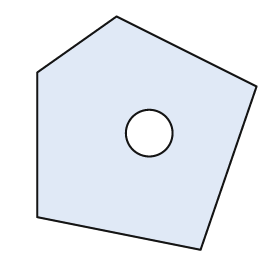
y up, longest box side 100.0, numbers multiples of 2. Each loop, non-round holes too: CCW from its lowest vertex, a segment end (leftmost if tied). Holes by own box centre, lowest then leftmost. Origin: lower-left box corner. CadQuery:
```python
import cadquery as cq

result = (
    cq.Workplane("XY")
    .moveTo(70.0, 0.0)
    .lineTo(94.0, 70.0)
    .lineTo(34.0, 100.0)
    .lineTo(0.0, 76.0)
    .lineTo(0.0, 14.0)
    .close()
    .moveTo(48.0, 50.0)
    .circle(10.0)
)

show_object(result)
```